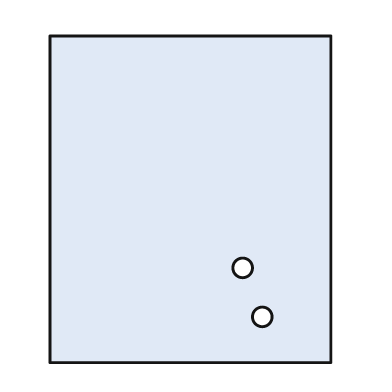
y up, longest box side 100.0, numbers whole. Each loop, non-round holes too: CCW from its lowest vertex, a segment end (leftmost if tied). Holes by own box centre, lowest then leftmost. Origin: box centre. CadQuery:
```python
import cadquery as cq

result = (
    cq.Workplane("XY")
    .moveTo(-43.0, -50.0)
    .lineTo(43.0, -50.0)
    .lineTo(43.0, 50.0)
    .lineTo(-43.0, 50.0)
    .close()
    .moveTo(22.0, -36.0)
    .circle(3.0)
    .moveTo(16.0, -21.0)
    .circle(3.0)
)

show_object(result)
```